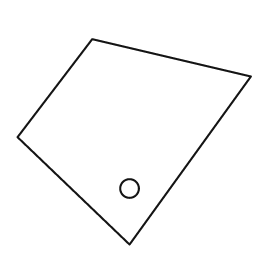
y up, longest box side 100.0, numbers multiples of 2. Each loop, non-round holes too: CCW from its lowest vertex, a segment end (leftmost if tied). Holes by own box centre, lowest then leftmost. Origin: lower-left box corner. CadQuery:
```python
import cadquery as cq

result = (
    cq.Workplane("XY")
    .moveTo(48.0, 0.0)
    .lineTo(100.0, 72.0)
    .lineTo(32.0, 88.0)
    .lineTo(0.0, 46.0)
    .close()
    .moveTo(48.0, 24.0)
    .circle(4.0)
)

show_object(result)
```